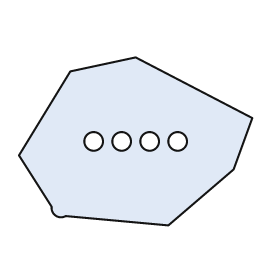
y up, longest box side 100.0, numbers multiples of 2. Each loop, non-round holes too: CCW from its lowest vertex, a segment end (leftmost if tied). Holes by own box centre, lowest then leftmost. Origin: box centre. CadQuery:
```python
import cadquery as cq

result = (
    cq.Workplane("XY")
    .moveTo(14.0, -36.0)
    .lineTo(42.0, -12.0)
    .lineTo(50.0, 10.0)
    .lineTo(0.0, 36.0)
    .lineTo(-28.0, 30.0)
    .lineTo(-50.0, -6.0)
    .lineTo(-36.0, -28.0)
    .threePointArc((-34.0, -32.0), (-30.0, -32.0))
    .close()
    .moveTo(-18.0, 0.0)
    .circle(4.0)
    .moveTo(-6.0, 0.0)
    .circle(4.0)
    .moveTo(6.0, 0.0)
    .circle(4.0)
    .moveTo(18.0, 0.0)
    .circle(4.0)
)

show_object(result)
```